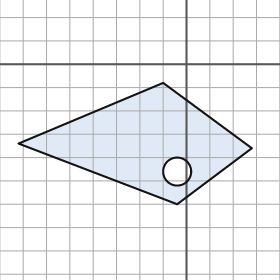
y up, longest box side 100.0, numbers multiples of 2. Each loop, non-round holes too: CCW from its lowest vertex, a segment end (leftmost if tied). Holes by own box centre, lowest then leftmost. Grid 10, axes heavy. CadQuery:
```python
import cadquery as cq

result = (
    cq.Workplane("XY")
    .moveTo(-4.0, -60.0)
    .lineTo(28.0, -36.0)
    .lineTo(-10.0, -8.0)
    .lineTo(-72.0, -34.0)
    .close()
    .moveTo(-4.0, -46.0)
    .circle(6.0)
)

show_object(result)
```